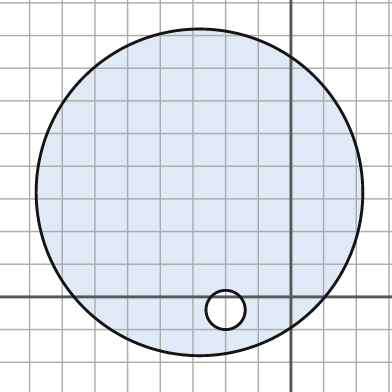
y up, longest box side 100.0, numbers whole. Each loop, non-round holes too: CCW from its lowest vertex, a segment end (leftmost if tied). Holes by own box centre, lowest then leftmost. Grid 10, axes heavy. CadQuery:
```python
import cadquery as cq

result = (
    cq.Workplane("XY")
    .moveTo(-28.0, 32.0)
    .circle(50.0)
    .moveTo(-20.0, -4.0)
    .circle(6.0)
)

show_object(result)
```